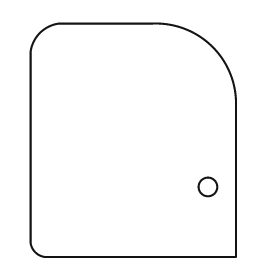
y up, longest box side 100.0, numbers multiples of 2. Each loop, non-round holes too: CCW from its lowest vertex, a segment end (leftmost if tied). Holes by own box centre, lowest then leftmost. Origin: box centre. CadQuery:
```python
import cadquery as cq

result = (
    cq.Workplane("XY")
    .moveTo(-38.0, -50.0)
    .lineTo(44.0, -50.0)
    .lineTo(44.0, 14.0)
    .threePointArc((34.0, 40.0), (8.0, 50.0))
    .lineTo(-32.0, 50.0)
    .threePointArc((-40.0, 46.0), (-44.0, 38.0))
    .lineTo(-44.0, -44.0)
    .threePointArc((-42.0, -48.0), (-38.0, -50.0))
    .close()
    .moveTo(32.0, -20.0)
    .circle(4.0)
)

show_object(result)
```